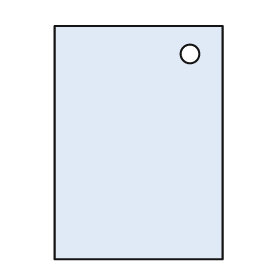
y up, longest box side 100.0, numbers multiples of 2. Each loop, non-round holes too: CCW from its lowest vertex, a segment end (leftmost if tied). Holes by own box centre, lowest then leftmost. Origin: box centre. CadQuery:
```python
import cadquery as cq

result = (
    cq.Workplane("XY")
    .moveTo(-36.0, -50.0)
    .lineTo(36.0, -50.0)
    .lineTo(36.0, 50.0)
    .lineTo(-36.0, 50.0)
    .close()
    .moveTo(22.0, 38.0)
    .circle(4.0)
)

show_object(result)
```